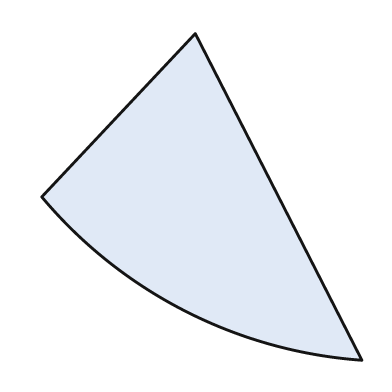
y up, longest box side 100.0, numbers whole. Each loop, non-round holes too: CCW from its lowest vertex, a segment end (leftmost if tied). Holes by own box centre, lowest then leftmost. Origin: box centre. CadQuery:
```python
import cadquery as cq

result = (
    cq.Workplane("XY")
    .moveTo(49.0, -50.0)
    .lineTo(-2.0, 50.0)
    .lineTo(-49.0, 0.0)
    .threePointArc((-5.0, -35.0), (49.0, -50.0))
    .close()
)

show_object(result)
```